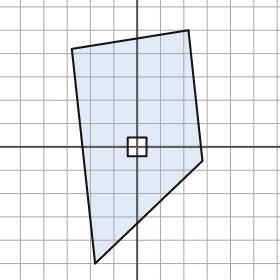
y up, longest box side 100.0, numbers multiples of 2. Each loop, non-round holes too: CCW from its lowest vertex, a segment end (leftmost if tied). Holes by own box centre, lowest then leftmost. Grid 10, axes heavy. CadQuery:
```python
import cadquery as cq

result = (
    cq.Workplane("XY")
    .moveTo(-18.0, -50.0)
    .lineTo(28.0, -6.0)
    .lineTo(22.0, 50.0)
    .lineTo(-28.0, 42.0)
    .close()
    .moveTo(-4.0, -4.0)
    .lineTo(4.0, -4.0)
    .lineTo(4.0, 4.0)
    .lineTo(-4.0, 4.0)
    .close()
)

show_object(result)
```